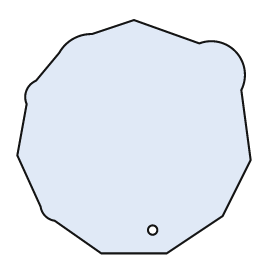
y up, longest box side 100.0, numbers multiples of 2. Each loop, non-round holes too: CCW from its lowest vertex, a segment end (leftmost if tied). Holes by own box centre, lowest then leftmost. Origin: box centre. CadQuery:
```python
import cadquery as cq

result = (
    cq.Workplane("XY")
    .moveTo(-14.0, -50.0)
    .lineTo(14.0, -50.0)
    .lineTo(38.0, -34.0)
    .lineTo(50.0, -10.0)
    .lineTo(46.0, 20.0)
    .threePointArc((44.0, 36.0), (28.0, 40.0))
    .lineTo(0.0, 50.0)
    .lineTo(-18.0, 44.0)
    .threePointArc((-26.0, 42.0), (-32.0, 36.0))
    .lineTo(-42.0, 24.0)
    .threePointArc((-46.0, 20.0), (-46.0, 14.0))
    .lineTo(-50.0, -8.0)
    .lineTo(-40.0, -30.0)
    .threePointArc((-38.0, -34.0), (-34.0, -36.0))
    .close()
    .moveTo(8.0, -40.0)
    .circle(2.0)
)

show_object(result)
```